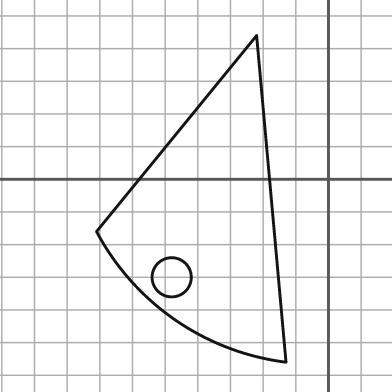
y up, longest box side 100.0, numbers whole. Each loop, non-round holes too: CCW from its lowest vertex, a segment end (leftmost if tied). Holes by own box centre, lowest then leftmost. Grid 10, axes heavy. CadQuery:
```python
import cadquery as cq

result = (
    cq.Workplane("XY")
    .moveTo(-13.0, -56.0)
    .lineTo(-22.0, 44.0)
    .lineTo(-71.0, -16.0)
    .threePointArc((-47.0, -43.0), (-13.0, -56.0))
    .close()
    .moveTo(-48.0, -30.0)
    .circle(6.0)
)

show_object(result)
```